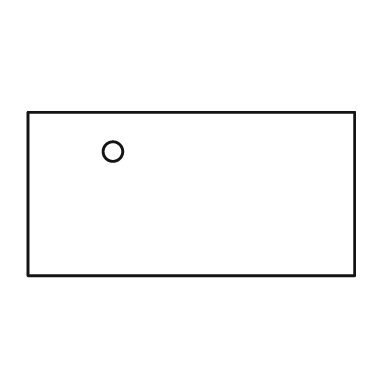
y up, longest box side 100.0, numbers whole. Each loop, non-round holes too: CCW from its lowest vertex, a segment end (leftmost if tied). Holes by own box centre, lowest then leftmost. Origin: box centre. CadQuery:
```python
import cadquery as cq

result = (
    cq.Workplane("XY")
    .moveTo(-50.0, -25.0)
    .lineTo(50.0, -25.0)
    .lineTo(50.0, 25.0)
    .lineTo(-50.0, 25.0)
    .close()
    .moveTo(-24.0, 13.0)
    .circle(3.0)
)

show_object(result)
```